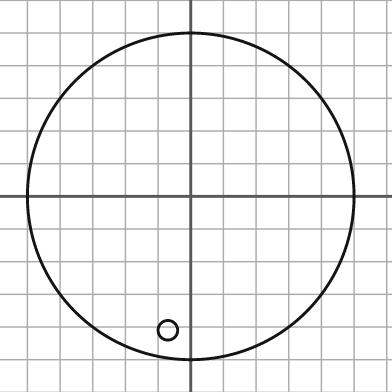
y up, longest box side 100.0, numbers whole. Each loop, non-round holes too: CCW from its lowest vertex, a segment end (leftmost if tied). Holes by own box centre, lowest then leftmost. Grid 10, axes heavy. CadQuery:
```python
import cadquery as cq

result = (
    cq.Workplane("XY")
    .moveTo(0.0, 0.0)
    .circle(50.0)
    .moveTo(-7.0, -41.0)
    .circle(3.0)
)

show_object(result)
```